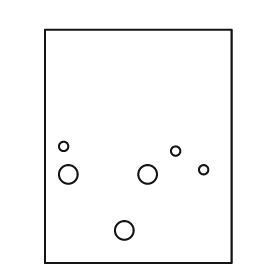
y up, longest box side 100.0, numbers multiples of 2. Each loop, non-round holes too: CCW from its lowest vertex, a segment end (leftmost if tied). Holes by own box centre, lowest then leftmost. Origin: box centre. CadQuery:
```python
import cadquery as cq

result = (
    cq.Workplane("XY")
    .moveTo(-40.0, -50.0)
    .lineTo(40.0, -50.0)
    .lineTo(40.0, 50.0)
    .lineTo(-40.0, 50.0)
    .close()
    .moveTo(-6.0, -36.0)
    .circle(4.0)
    .moveTo(-30.0, -12.0)
    .circle(4.0)
    .moveTo(4.0, -12.0)
    .circle(4.0)
    .moveTo(28.0, -10.0)
    .circle(2.0)
    .moveTo(16.0, -2.0)
    .circle(2.0)
    .moveTo(-32.0, 0.0)
    .circle(2.0)
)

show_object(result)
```